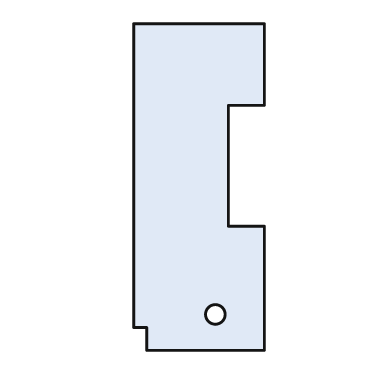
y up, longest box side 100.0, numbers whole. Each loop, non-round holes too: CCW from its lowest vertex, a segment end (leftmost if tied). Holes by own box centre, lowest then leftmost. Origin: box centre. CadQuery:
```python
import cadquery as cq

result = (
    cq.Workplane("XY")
    .moveTo(-16.0, -50.0)
    .lineTo(20.0, -50.0)
    .lineTo(20.0, -12.0)
    .lineTo(9.0, -12.0)
    .lineTo(9.0, 25.0)
    .lineTo(20.0, 25.0)
    .lineTo(20.0, 50.0)
    .lineTo(-20.0, 50.0)
    .lineTo(-20.0, -43.0)
    .lineTo(-16.0, -43.0)
    .close()
    .moveTo(5.0, -39.0)
    .circle(3.0)
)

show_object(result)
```